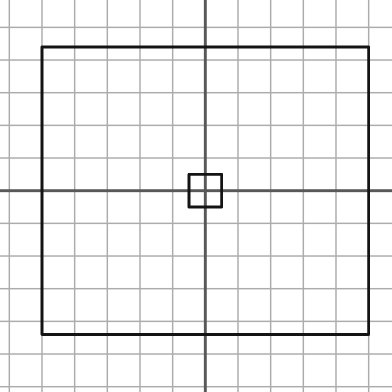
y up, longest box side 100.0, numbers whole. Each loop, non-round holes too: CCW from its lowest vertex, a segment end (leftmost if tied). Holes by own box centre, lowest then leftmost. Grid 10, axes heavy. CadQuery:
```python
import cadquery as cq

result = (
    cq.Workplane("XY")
    .moveTo(-50.0, -44.0)
    .lineTo(50.0, -44.0)
    .lineTo(50.0, 44.0)
    .lineTo(-50.0, 44.0)
    .close()
    .moveTo(-5.0, -5.0)
    .lineTo(5.0, -5.0)
    .lineTo(5.0, 5.0)
    .lineTo(-5.0, 5.0)
    .close()
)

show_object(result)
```